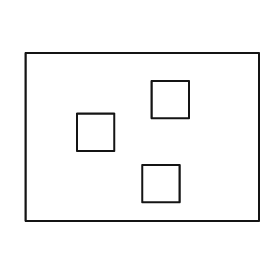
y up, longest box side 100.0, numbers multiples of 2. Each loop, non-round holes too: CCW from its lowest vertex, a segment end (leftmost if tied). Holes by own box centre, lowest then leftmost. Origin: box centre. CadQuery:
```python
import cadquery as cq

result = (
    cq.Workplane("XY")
    .moveTo(-50.0, -36.0)
    .lineTo(50.0, -36.0)
    .lineTo(50.0, 36.0)
    .lineTo(-50.0, 36.0)
    .close()
    .moveTo(0.0, -28.0)
    .lineTo(16.0, -28.0)
    .lineTo(16.0, -12.0)
    .lineTo(0.0, -12.0)
    .close()
    .moveTo(-28.0, -6.0)
    .lineTo(-12.0, -6.0)
    .lineTo(-12.0, 10.0)
    .lineTo(-28.0, 10.0)
    .close()
    .moveTo(4.0, 8.0)
    .lineTo(20.0, 8.0)
    .lineTo(20.0, 24.0)
    .lineTo(4.0, 24.0)
    .close()
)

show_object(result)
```